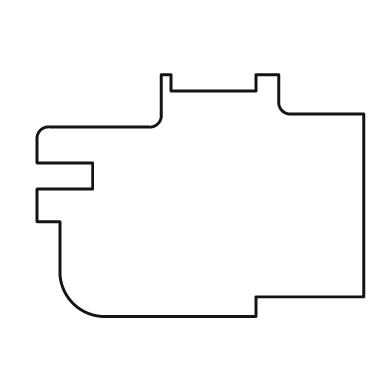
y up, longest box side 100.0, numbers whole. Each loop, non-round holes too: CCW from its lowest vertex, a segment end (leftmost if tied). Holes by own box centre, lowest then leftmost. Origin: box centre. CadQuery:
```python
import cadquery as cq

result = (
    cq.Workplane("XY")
    .moveTo(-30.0, -37.0)
    .lineTo(17.0, -37.0)
    .lineTo(17.0, -31.0)
    .lineTo(50.0, -31.0)
    .lineTo(50.0, 25.0)
    .lineTo(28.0, 25.0)
    .threePointArc((25.0, 26.0), (24.0, 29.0))
    .lineTo(24.0, 37.0)
    .lineTo(17.0, 37.0)
    .lineTo(17.0, 32.0)
    .lineTo(-9.0, 32.0)
    .lineTo(-9.0, 37.0)
    .lineTo(-12.0, 37.0)
    .lineTo(-12.0, 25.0)
    .threePointArc((-13.0, 22.0), (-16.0, 21.0))
    .lineTo(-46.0, 21.0)
    .threePointArc((-49.0, 20.0), (-50.0, 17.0))
    .lineTo(-50.0, 10.0)
    .lineTo(-33.0, 10.0)
    .lineTo(-33.0, 2.0)
    .lineTo(-50.0, 2.0)
    .lineTo(-50.0, -8.0)
    .lineTo(-43.0, -8.0)
    .lineTo(-43.0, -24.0)
    .threePointArc((-39.0, -33.0), (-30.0, -37.0))
    .close()
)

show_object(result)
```